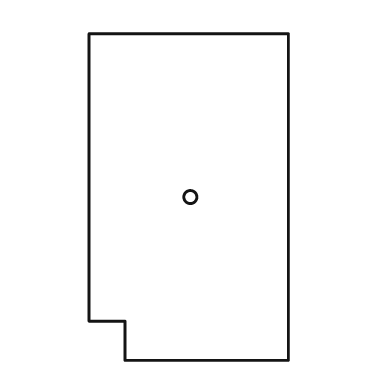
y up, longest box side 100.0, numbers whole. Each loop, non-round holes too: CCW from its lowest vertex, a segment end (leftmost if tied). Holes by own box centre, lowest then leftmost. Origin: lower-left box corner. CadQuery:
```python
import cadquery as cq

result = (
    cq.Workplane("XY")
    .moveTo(11.0, 0.0)
    .lineTo(61.0, 0.0)
    .lineTo(61.0, 100.0)
    .lineTo(0.0, 100.0)
    .lineTo(0.0, 12.0)
    .lineTo(11.0, 12.0)
    .close()
    .moveTo(31.0, 50.0)
    .circle(2.0)
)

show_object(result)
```